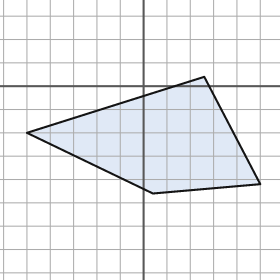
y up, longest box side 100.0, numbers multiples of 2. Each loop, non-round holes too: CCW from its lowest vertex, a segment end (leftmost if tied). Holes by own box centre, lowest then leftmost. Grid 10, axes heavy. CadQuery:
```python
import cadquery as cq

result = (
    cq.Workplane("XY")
    .moveTo(4.0, -46.0)
    .lineTo(50.0, -42.0)
    .lineTo(26.0, 4.0)
    .lineTo(-50.0, -20.0)
    .close()
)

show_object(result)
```